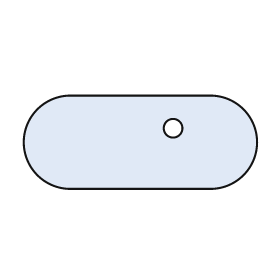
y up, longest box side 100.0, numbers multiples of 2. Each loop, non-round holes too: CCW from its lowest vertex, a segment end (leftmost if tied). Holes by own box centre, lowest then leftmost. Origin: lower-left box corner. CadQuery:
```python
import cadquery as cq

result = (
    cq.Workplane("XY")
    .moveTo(20.0, 0.0)
    .lineTo(80.0, 0.0)
    .threePointArc((100.0, 20.0), (80.0, 40.0))
    .lineTo(20.0, 40.0)
    .threePointArc((0.0, 20.0), (20.0, 0.0))
    .close()
    .moveTo(64.0, 26.0)
    .circle(4.0)
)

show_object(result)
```